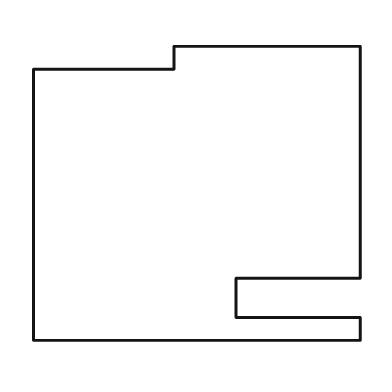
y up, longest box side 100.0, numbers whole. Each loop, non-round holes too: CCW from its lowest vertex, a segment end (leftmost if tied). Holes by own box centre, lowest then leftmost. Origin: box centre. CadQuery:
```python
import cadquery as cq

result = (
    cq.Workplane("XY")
    .moveTo(-50.0, -45.0)
    .lineTo(50.0, -45.0)
    .lineTo(50.0, -38.0)
    .lineTo(12.0, -38.0)
    .lineTo(12.0, -26.0)
    .lineTo(50.0, -26.0)
    .lineTo(50.0, 45.0)
    .lineTo(-7.0, 45.0)
    .lineTo(-7.0, 38.0)
    .lineTo(-50.0, 38.0)
    .close()
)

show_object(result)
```